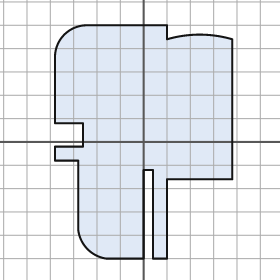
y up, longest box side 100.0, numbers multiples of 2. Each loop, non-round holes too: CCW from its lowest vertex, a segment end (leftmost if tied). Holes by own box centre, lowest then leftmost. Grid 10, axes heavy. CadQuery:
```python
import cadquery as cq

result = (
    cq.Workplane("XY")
    .moveTo(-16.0, -50.0)
    .lineTo(0.0, -50.0)
    .lineTo(0.0, -12.0)
    .lineTo(4.0, -12.0)
    .lineTo(4.0, -50.0)
    .lineTo(10.0, -50.0)
    .lineTo(10.0, -16.0)
    .lineTo(38.0, -16.0)
    .lineTo(38.0, 44.0)
    .threePointArc((24.0, 46.0), (10.0, 44.0))
    .lineTo(10.0, 50.0)
    .lineTo(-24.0, 50.0)
    .threePointArc((-34.0, 46.0), (-38.0, 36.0))
    .lineTo(-38.0, 8.0)
    .lineTo(-26.0, 8.0)
    .lineTo(-26.0, -2.0)
    .lineTo(-38.0, -2.0)
    .lineTo(-38.0, -8.0)
    .lineTo(-28.0, -8.0)
    .lineTo(-28.0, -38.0)
    .threePointArc((-24.0, -46.0), (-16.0, -50.0))
    .close()
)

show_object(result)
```